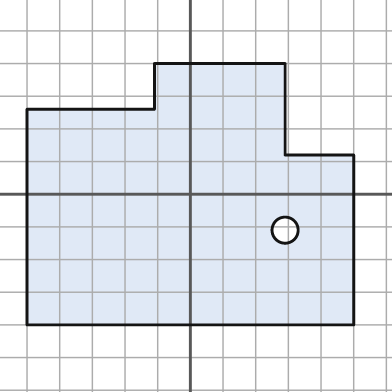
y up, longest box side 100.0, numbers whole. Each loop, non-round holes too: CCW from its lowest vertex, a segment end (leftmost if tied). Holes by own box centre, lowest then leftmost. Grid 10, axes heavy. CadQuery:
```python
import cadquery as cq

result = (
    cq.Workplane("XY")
    .moveTo(-50.0, -40.0)
    .lineTo(50.0, -40.0)
    .lineTo(50.0, 12.0)
    .lineTo(29.0, 12.0)
    .lineTo(29.0, 40.0)
    .lineTo(-11.0, 40.0)
    .lineTo(-11.0, 26.0)
    .lineTo(-50.0, 26.0)
    .close()
    .moveTo(29.0, -11.0)
    .circle(4.0)
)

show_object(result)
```